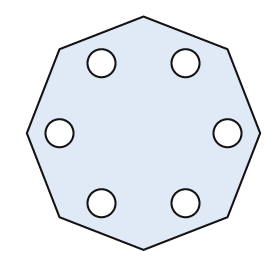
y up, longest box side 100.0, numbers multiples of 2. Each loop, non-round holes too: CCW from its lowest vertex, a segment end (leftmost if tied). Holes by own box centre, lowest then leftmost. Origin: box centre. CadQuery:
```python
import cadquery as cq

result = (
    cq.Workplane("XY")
    .moveTo(0.0, -50.0)
    .lineTo(36.0, -36.0)
    .lineTo(50.0, 0.0)
    .lineTo(36.0, 36.0)
    .lineTo(0.0, 50.0)
    .lineTo(-36.0, 36.0)
    .lineTo(-50.0, 0.0)
    .lineTo(-36.0, -36.0)
    .close()
    .moveTo(-18.0, -30.0)
    .circle(6.0)
    .moveTo(18.0, -30.0)
    .circle(6.0)
    .moveTo(-36.0, 0.0)
    .circle(6.0)
    .moveTo(36.0, 0.0)
    .circle(6.0)
    .moveTo(-18.0, 30.0)
    .circle(6.0)
    .moveTo(18.0, 30.0)
    .circle(6.0)
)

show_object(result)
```